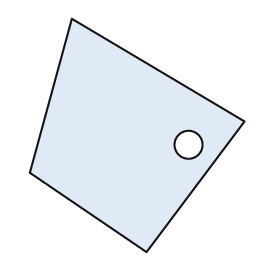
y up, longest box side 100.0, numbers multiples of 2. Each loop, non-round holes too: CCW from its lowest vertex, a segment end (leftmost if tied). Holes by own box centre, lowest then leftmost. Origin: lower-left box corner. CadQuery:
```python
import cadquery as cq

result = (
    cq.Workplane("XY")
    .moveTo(50.0, 0.0)
    .lineTo(92.0, 56.0)
    .lineTo(18.0, 100.0)
    .lineTo(0.0, 34.0)
    .close()
    .moveTo(68.0, 46.0)
    .circle(6.0)
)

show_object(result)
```